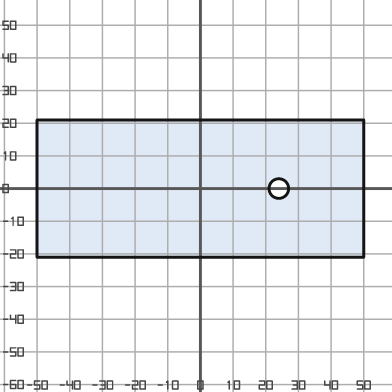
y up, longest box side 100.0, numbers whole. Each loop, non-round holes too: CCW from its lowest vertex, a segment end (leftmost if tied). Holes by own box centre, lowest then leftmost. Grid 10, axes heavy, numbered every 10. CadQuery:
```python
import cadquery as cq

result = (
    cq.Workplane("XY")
    .moveTo(-50.0, -21.0)
    .lineTo(50.0, -21.0)
    .lineTo(50.0, 21.0)
    .lineTo(-50.0, 21.0)
    .close()
    .moveTo(24.0, 0.0)
    .circle(3.0)
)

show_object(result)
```